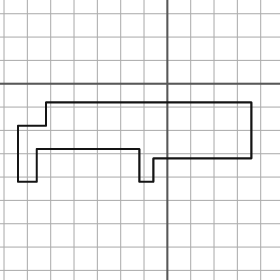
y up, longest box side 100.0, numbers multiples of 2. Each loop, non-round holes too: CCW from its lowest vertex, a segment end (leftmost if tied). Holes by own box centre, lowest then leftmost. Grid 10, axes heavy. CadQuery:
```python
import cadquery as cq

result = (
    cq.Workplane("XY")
    .moveTo(-64.0, -42.0)
    .lineTo(-56.0, -42.0)
    .lineTo(-56.0, -28.0)
    .lineTo(-12.0, -28.0)
    .lineTo(-12.0, -42.0)
    .lineTo(-6.0, -42.0)
    .lineTo(-6.0, -32.0)
    .lineTo(36.0, -32.0)
    .lineTo(36.0, -8.0)
    .lineTo(-52.0, -8.0)
    .lineTo(-52.0, -18.0)
    .lineTo(-64.0, -18.0)
    .close()
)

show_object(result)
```